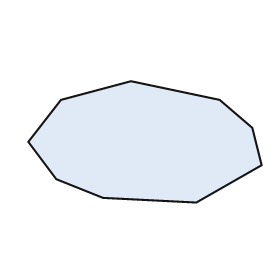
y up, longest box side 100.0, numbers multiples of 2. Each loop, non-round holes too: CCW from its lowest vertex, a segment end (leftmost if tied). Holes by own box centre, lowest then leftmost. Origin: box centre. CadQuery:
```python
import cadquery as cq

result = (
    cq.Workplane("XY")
    .moveTo(22.0, -26.0)
    .lineTo(50.0, -10.0)
    .lineTo(46.0, 6.0)
    .lineTo(32.0, 18.0)
    .lineTo(-6.0, 26.0)
    .lineTo(-36.0, 18.0)
    .lineTo(-50.0, 0.0)
    .lineTo(-38.0, -16.0)
    .lineTo(-18.0, -24.0)
    .close()
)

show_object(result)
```